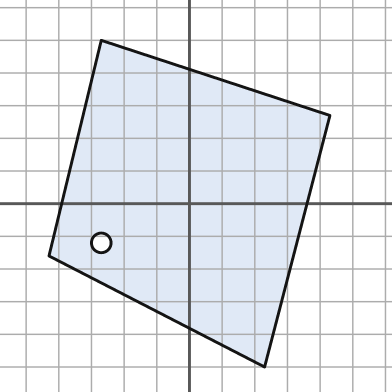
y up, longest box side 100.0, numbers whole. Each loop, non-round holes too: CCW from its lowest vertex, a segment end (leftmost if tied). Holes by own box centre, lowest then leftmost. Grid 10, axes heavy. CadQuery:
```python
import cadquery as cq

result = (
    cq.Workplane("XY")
    .moveTo(23.0, -50.0)
    .lineTo(43.0, 27.0)
    .lineTo(-27.0, 50.0)
    .lineTo(-43.0, -16.0)
    .close()
    .moveTo(-27.0, -12.0)
    .circle(3.0)
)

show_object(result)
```